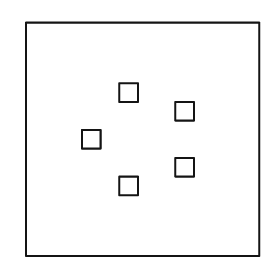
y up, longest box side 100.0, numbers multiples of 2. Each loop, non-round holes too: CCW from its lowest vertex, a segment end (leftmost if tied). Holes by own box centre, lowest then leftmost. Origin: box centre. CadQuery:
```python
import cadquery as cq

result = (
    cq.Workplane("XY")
    .moveTo(-50.0, -50.0)
    .lineTo(50.0, -50.0)
    .lineTo(50.0, 50.0)
    .lineTo(-50.0, 50.0)
    .close()
    .moveTo(-10.0, -24.0)
    .lineTo(-2.0, -24.0)
    .lineTo(-2.0, -16.0)
    .lineTo(-10.0, -16.0)
    .close()
    .moveTo(14.0, -16.0)
    .lineTo(22.0, -16.0)
    .lineTo(22.0, -8.0)
    .lineTo(14.0, -8.0)
    .close()
    .moveTo(-26.0, -4.0)
    .lineTo(-18.0, -4.0)
    .lineTo(-18.0, 4.0)
    .lineTo(-26.0, 4.0)
    .close()
    .moveTo(14.0, 8.0)
    .lineTo(22.0, 8.0)
    .lineTo(22.0, 16.0)
    .lineTo(14.0, 16.0)
    .close()
    .moveTo(-10.0, 16.0)
    .lineTo(-2.0, 16.0)
    .lineTo(-2.0, 24.0)
    .lineTo(-10.0, 24.0)
    .close()
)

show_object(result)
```